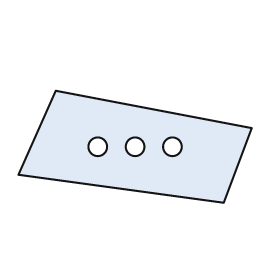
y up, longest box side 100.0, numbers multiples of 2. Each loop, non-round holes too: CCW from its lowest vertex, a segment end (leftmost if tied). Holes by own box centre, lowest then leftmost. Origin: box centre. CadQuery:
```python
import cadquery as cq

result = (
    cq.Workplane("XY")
    .moveTo(38.0, -24.0)
    .lineTo(50.0, 8.0)
    .lineTo(-34.0, 24.0)
    .lineTo(-50.0, -12.0)
    .close()
    .moveTo(-16.0, 0.0)
    .circle(4.0)
    .moveTo(0.0, 0.0)
    .circle(4.0)
    .moveTo(16.0, 0.0)
    .circle(4.0)
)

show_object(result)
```